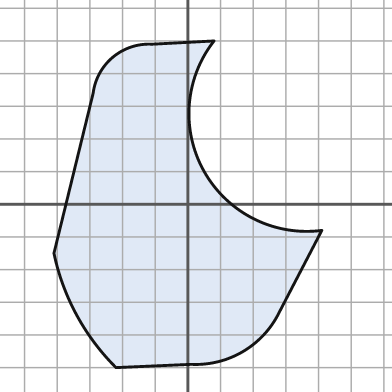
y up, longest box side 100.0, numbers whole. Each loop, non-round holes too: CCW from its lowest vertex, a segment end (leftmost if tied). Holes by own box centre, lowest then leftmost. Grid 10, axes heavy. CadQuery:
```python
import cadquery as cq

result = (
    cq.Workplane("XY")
    .moveTo(-22.0, -50.0)
    .lineTo(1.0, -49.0)
    .threePointArc((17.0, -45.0), (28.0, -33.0))
    .lineTo(41.0, -8.0)
    .threePointArc((5.0, 10.0), (8.0, 50.0))
    .lineTo(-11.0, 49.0)
    .threePointArc((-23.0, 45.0), (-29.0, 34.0))
    .lineTo(-41.0, -15.0)
    .threePointArc((-34.0, -34.0), (-22.0, -50.0))
    .close()
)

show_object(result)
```